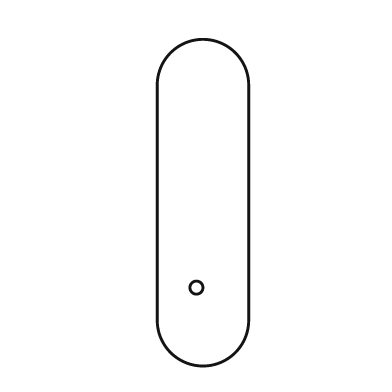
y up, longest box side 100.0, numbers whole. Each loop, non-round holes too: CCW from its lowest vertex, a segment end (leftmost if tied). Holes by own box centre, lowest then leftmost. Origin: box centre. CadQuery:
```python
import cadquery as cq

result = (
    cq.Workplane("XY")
    .moveTo(-14.0, -36.0)
    .threePointArc((0.0, -50.0), (14.0, -36.0))
    .lineTo(14.0, 36.0)
    .threePointArc((0.0, 50.0), (-14.0, 36.0))
    .close()
    .moveTo(-2.0, -26.0)
    .circle(2.0)
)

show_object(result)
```